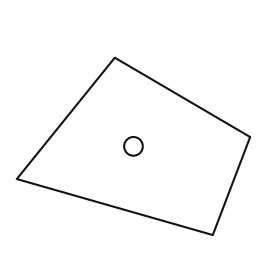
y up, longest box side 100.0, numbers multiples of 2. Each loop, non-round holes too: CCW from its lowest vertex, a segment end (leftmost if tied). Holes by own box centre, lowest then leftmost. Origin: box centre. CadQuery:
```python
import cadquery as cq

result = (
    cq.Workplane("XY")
    .moveTo(34.0, -38.0)
    .lineTo(50.0, 4.0)
    .lineTo(-8.0, 38.0)
    .lineTo(-50.0, -14.0)
    .close()
    .moveTo(0.0, 0.0)
    .circle(4.0)
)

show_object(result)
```